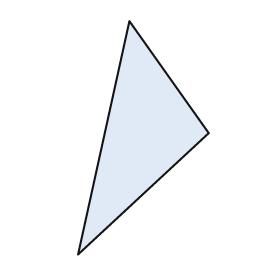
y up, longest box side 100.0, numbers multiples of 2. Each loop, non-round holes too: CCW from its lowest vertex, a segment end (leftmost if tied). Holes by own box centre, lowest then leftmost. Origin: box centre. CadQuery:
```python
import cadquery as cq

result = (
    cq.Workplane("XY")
    .moveTo(-28.0, -50.0)
    .lineTo(28.0, 2.0)
    .lineTo(-6.0, 50.0)
    .close()
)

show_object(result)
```